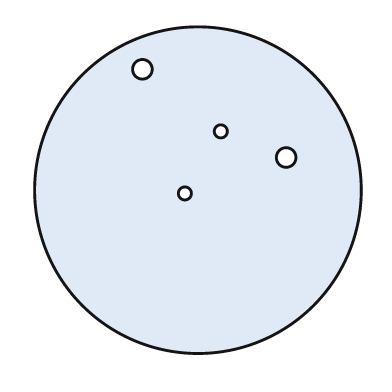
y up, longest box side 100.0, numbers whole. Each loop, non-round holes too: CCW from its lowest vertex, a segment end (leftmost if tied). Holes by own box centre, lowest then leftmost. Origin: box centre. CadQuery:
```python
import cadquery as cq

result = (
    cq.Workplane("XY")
    .moveTo(0.0, 0.0)
    .circle(50.0)
    .moveTo(-4.0, -1.0)
    .circle(2.0)
    .moveTo(27.0, 10.0)
    .circle(3.0)
    .moveTo(7.0, 18.0)
    .circle(2.0)
    .moveTo(-17.0, 37.0)
    .circle(3.0)
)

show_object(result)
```